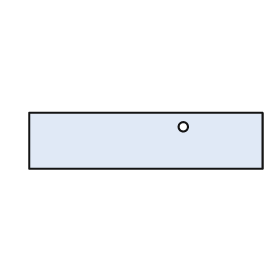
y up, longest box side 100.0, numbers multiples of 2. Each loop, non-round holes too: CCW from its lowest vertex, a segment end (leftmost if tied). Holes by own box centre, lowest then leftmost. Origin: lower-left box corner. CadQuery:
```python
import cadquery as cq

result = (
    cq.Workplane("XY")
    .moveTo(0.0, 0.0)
    .lineTo(100.0, 0.0)
    .lineTo(100.0, 24.0)
    .lineTo(0.0, 24.0)
    .close()
    .moveTo(66.0, 18.0)
    .circle(2.0)
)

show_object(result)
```